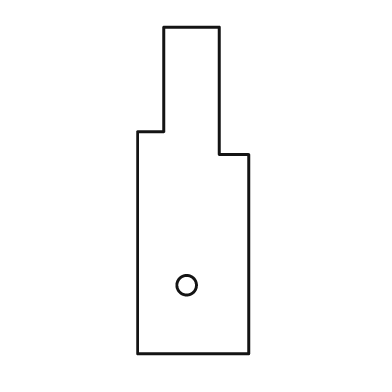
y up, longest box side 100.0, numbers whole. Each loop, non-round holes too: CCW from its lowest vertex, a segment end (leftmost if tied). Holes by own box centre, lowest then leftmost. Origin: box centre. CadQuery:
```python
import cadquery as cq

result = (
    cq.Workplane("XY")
    .moveTo(-17.0, -50.0)
    .lineTo(17.0, -50.0)
    .lineTo(17.0, 11.0)
    .lineTo(8.0, 11.0)
    .lineTo(8.0, 50.0)
    .lineTo(-9.0, 50.0)
    .lineTo(-9.0, 18.0)
    .lineTo(-17.0, 18.0)
    .close()
    .moveTo(-2.0, -29.0)
    .circle(3.0)
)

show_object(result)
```